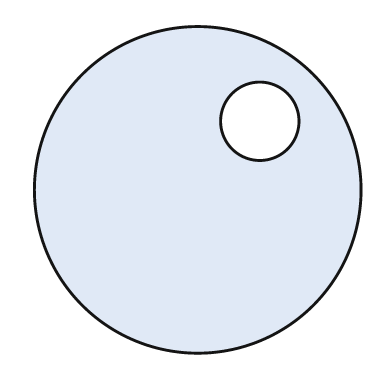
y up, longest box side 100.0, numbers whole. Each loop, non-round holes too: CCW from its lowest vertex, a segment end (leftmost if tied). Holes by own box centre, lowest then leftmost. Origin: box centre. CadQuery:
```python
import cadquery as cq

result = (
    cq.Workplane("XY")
    .moveTo(0.0, 0.0)
    .circle(50.0)
    .moveTo(19.0, 21.0)
    .circle(12.0)
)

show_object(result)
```